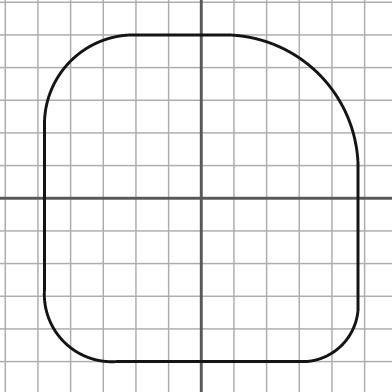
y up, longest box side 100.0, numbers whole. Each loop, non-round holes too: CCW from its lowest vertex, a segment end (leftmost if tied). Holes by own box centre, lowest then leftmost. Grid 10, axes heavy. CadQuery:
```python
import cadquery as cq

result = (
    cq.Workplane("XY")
    .moveTo(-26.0, -50.0)
    .lineTo(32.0, -50.0)
    .threePointArc((43.0, -45.0), (48.0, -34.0))
    .lineTo(48.0, 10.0)
    .threePointArc((36.0, 38.0), (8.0, 50.0))
    .lineTo(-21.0, 50.0)
    .threePointArc((-40.0, 42.0), (-48.0, 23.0))
    .lineTo(-48.0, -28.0)
    .threePointArc((-42.0, -44.0), (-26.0, -50.0))
    .close()
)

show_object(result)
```